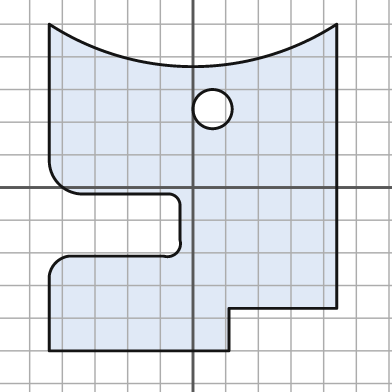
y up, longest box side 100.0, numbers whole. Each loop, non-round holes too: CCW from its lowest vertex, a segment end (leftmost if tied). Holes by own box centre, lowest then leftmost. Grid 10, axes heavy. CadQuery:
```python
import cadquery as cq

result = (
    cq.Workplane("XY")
    .moveTo(-44.0, -50.0)
    .lineTo(11.0, -50.0)
    .lineTo(11.0, -37.0)
    .lineTo(44.0, -37.0)
    .lineTo(44.0, 50.0)
    .threePointArc((0.0, 37.0), (-44.0, 50.0))
    .lineTo(-44.0, 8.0)
    .threePointArc((-41.0, 1.0), (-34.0, -2.0))
    .lineTo(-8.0, -2.0)
    .threePointArc((-5.0, -3.0), (-4.0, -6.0))
    .lineTo(-4.0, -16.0)
    .threePointArc((-5.0, -20.0), (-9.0, -21.0))
    .lineTo(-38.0, -21.0)
    .threePointArc((-42.0, -23.0), (-44.0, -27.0))
    .close()
    .moveTo(6.0, 24.0)
    .circle(6.0)
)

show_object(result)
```